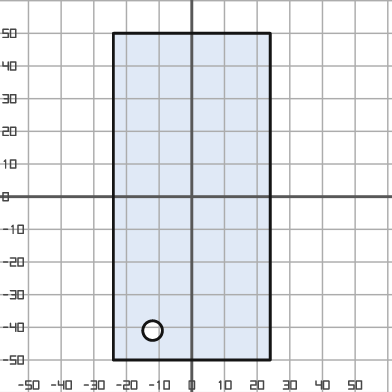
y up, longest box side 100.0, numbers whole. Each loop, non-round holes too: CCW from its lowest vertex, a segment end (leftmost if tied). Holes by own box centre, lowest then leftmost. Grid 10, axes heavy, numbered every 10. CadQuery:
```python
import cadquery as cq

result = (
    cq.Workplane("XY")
    .moveTo(-24.0, -50.0)
    .lineTo(24.0, -50.0)
    .lineTo(24.0, 50.0)
    .lineTo(-24.0, 50.0)
    .close()
    .moveTo(-12.0, -41.0)
    .circle(3.0)
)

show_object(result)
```